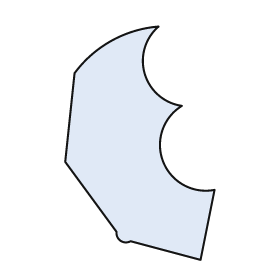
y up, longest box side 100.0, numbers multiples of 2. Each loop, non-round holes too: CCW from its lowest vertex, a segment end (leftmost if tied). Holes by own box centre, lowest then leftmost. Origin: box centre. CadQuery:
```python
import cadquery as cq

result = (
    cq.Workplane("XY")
    .moveTo(26.0, -50.0)
    .lineTo(32.0, -20.0)
    .threePointArc((10.0, -8.0), (18.0, 16.0))
    .threePointArc((2.0, 30.0), (8.0, 50.0))
    .threePointArc((-12.0, 44.0), (-28.0, 30.0))
    .lineTo(-32.0, -8.0)
    .lineTo(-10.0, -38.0)
    .threePointArc((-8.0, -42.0), (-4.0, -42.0))
    .close()
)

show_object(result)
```